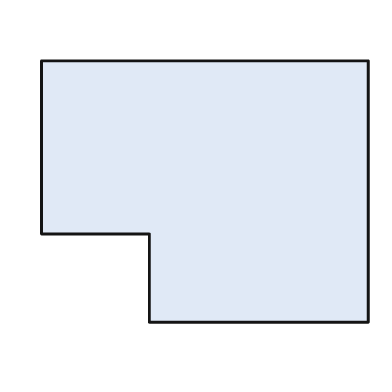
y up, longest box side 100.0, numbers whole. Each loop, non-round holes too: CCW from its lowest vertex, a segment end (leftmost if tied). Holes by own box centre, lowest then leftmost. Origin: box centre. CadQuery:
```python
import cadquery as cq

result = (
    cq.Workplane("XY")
    .moveTo(-17.0, -40.0)
    .lineTo(50.0, -40.0)
    .lineTo(50.0, 40.0)
    .lineTo(-50.0, 40.0)
    .lineTo(-50.0, -13.0)
    .lineTo(-17.0, -13.0)
    .close()
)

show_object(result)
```